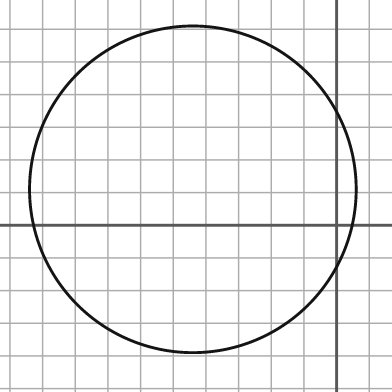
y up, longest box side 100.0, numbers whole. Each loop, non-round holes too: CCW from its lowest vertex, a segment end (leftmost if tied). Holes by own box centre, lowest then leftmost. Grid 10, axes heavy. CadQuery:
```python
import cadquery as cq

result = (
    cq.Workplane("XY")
    .moveTo(-44.0, 11.0)
    .circle(50.0)
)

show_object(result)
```